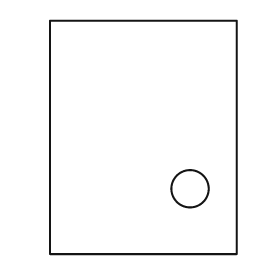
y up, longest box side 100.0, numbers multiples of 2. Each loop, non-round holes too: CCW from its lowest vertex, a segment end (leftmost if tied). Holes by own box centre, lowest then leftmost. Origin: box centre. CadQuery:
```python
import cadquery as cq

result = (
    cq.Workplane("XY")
    .moveTo(-40.0, -50.0)
    .lineTo(40.0, -50.0)
    .lineTo(40.0, 50.0)
    .lineTo(-40.0, 50.0)
    .close()
    .moveTo(20.0, -22.0)
    .circle(8.0)
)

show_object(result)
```